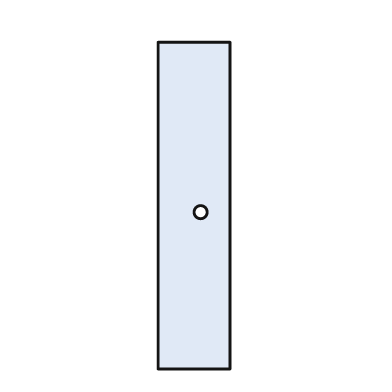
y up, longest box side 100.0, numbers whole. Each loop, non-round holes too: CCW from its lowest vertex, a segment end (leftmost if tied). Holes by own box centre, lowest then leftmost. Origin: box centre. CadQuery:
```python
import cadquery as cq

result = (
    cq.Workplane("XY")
    .moveTo(-11.0, -50.0)
    .lineTo(11.0, -50.0)
    .lineTo(11.0, 50.0)
    .lineTo(-11.0, 50.0)
    .close()
    .moveTo(2.0, -2.0)
    .circle(2.0)
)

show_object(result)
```